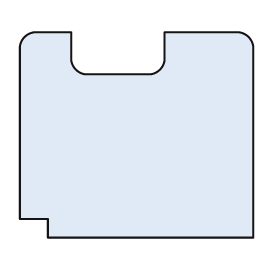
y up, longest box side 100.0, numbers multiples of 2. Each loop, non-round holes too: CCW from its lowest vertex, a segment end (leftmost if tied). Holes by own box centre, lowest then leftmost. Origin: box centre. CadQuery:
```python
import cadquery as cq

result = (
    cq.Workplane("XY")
    .moveTo(-38.0, -44.0)
    .lineTo(50.0, -44.0)
    .lineTo(50.0, 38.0)
    .threePointArc((48.0, 42.0), (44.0, 44.0))
    .lineTo(12.0, 44.0)
    .lineTo(12.0, 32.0)
    .threePointArc((10.0, 28.0), (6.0, 26.0))
    .lineTo(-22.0, 26.0)
    .threePointArc((-26.0, 28.0), (-28.0, 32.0))
    .lineTo(-28.0, 44.0)
    .lineTo(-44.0, 44.0)
    .threePointArc((-48.0, 42.0), (-50.0, 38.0))
    .lineTo(-50.0, -36.0)
    .lineTo(-38.0, -36.0)
    .close()
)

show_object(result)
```